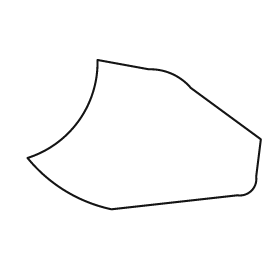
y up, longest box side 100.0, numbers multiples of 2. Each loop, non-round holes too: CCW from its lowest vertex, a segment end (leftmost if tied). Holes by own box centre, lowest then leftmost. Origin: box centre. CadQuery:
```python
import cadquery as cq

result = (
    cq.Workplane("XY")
    .moveTo(-14.0, -32.0)
    .lineTo(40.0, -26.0)
    .threePointArc((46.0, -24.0), (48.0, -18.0))
    .lineTo(50.0, -2.0)
    .lineTo(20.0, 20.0)
    .threePointArc((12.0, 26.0), (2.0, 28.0))
    .lineTo(-20.0, 32.0)
    .threePointArc((-28.0, 6.0), (-50.0, -10.0))
    .threePointArc((-34.0, -24.0), (-14.0, -32.0))
    .close()
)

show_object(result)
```